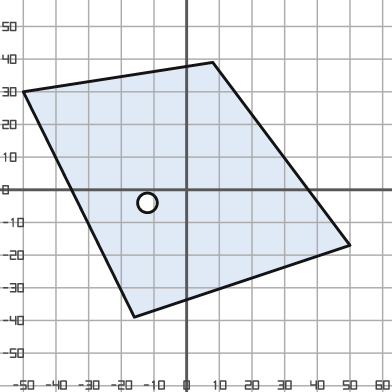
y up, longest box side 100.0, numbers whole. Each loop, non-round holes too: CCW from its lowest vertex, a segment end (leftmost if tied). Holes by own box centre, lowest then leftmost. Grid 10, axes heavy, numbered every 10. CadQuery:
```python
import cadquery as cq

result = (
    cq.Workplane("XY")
    .moveTo(-16.0, -39.0)
    .lineTo(50.0, -17.0)
    .lineTo(8.0, 39.0)
    .lineTo(-50.0, 30.0)
    .close()
    .moveTo(-12.0, -4.0)
    .circle(3.0)
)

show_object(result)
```